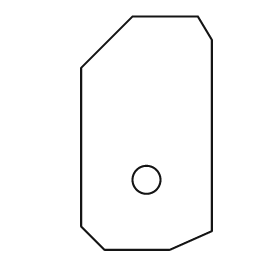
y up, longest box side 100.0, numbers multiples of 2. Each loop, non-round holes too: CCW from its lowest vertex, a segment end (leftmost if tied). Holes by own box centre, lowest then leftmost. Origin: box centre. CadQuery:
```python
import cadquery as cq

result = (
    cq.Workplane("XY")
    .moveTo(-18.0, -50.0)
    .lineTo(10.0, -50.0)
    .lineTo(28.0, -42.0)
    .lineTo(28.0, 40.0)
    .lineTo(22.0, 50.0)
    .lineTo(-6.0, 50.0)
    .lineTo(-28.0, 28.0)
    .lineTo(-28.0, -40.0)
    .close()
    .moveTo(0.0, -20.0)
    .circle(6.0)
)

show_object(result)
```